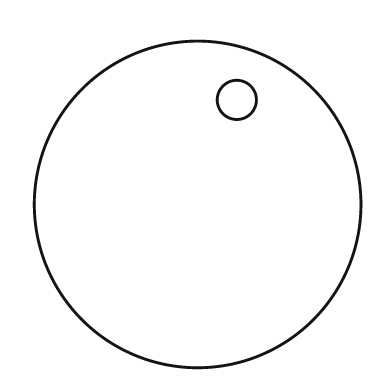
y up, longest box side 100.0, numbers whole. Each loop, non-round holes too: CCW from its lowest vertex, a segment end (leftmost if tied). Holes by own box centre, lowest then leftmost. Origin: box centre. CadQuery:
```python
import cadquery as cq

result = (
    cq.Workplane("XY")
    .moveTo(0.0, 0.0)
    .circle(50.0)
    .moveTo(12.0, 32.0)
    .circle(6.0)
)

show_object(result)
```